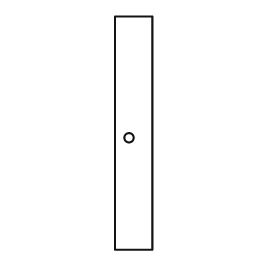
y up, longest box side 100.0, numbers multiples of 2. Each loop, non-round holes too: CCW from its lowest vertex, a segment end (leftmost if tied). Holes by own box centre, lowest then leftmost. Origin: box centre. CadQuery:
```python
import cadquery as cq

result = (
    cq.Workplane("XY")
    .moveTo(-8.0, -50.0)
    .lineTo(8.0, -50.0)
    .lineTo(8.0, 50.0)
    .lineTo(-8.0, 50.0)
    .close()
    .moveTo(-2.0, -2.0)
    .circle(2.0)
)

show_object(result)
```